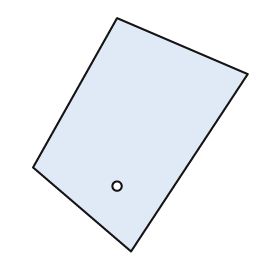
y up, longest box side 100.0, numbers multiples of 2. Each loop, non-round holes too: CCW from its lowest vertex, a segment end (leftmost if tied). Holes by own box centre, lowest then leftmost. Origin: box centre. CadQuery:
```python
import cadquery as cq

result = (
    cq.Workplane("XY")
    .moveTo(-4.0, -50.0)
    .lineTo(46.0, 26.0)
    .lineTo(-10.0, 50.0)
    .lineTo(-46.0, -14.0)
    .close()
    .moveTo(-10.0, -22.0)
    .circle(2.0)
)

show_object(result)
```